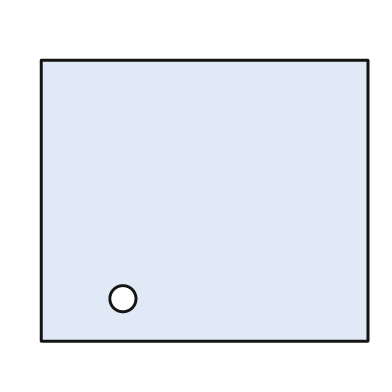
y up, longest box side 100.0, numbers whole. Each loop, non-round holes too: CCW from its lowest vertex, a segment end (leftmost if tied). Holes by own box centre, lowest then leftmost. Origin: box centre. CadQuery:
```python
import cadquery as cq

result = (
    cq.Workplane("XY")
    .moveTo(-50.0, -43.0)
    .lineTo(50.0, -43.0)
    .lineTo(50.0, 43.0)
    .lineTo(-50.0, 43.0)
    .close()
    .moveTo(-25.0, -30.0)
    .circle(4.0)
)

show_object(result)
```